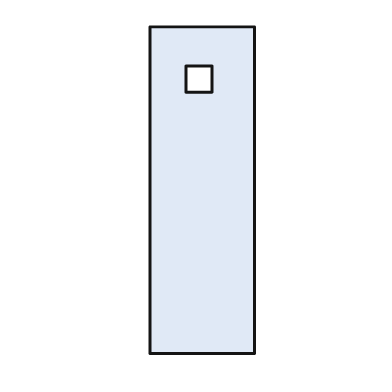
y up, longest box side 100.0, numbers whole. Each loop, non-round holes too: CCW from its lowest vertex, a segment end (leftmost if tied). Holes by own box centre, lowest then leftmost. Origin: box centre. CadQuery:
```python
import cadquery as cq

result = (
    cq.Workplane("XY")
    .moveTo(-16.0, -50.0)
    .lineTo(16.0, -50.0)
    .lineTo(16.0, 50.0)
    .lineTo(-16.0, 50.0)
    .close()
    .moveTo(-5.0, 30.0)
    .lineTo(3.0, 30.0)
    .lineTo(3.0, 38.0)
    .lineTo(-5.0, 38.0)
    .close()
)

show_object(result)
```